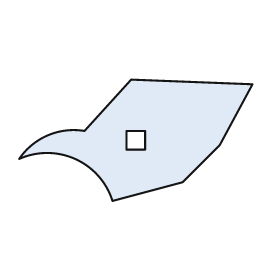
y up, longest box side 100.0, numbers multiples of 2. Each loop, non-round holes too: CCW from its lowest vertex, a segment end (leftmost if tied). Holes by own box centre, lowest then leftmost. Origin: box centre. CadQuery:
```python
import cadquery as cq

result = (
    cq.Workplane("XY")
    .moveTo(-10.0, -26.0)
    .lineTo(20.0, -18.0)
    .lineTo(36.0, -2.0)
    .lineTo(50.0, 24.0)
    .lineTo(-2.0, 26.0)
    .lineTo(-22.0, 4.0)
    .threePointArc((-38.0, 2.0), (-50.0, -8.0))
    .threePointArc((-26.0, -8.0), (-10.0, -26.0))
    .close()
    .moveTo(-4.0, -4.0)
    .lineTo(4.0, -4.0)
    .lineTo(4.0, 4.0)
    .lineTo(-4.0, 4.0)
    .close()
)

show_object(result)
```